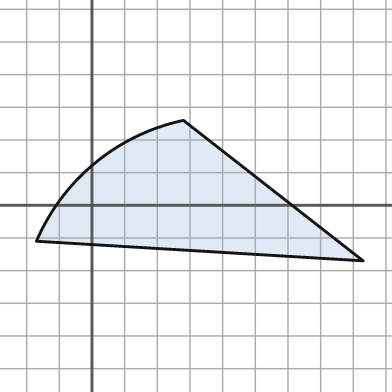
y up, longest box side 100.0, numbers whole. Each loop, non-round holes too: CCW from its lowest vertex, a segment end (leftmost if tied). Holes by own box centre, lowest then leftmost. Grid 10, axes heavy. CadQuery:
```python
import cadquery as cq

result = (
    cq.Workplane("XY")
    .moveTo(83.0, -17.0)
    .lineTo(28.0, 26.0)
    .threePointArc((1.0, 13.0), (-17.0, -11.0))
    .close()
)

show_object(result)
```